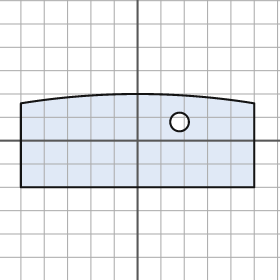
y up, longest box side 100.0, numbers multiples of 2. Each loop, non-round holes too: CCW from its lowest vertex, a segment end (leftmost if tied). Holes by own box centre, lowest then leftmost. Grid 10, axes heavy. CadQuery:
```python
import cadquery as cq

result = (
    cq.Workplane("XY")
    .moveTo(-50.0, -20.0)
    .lineTo(50.0, -20.0)
    .lineTo(50.0, 16.0)
    .threePointArc((0.0, 20.0), (-50.0, 16.0))
    .close()
    .moveTo(18.0, 8.0)
    .circle(4.0)
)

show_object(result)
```